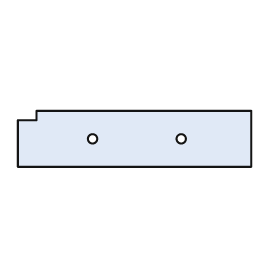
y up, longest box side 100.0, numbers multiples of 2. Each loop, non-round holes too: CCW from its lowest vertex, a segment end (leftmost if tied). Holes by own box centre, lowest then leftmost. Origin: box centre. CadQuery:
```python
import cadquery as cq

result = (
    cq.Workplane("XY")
    .moveTo(-50.0, -12.0)
    .lineTo(50.0, -12.0)
    .lineTo(50.0, 12.0)
    .lineTo(-42.0, 12.0)
    .lineTo(-42.0, 8.0)
    .lineTo(-50.0, 8.0)
    .close()
    .moveTo(-18.0, 0.0)
    .circle(2.0)
    .moveTo(20.0, 0.0)
    .circle(2.0)
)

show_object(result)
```